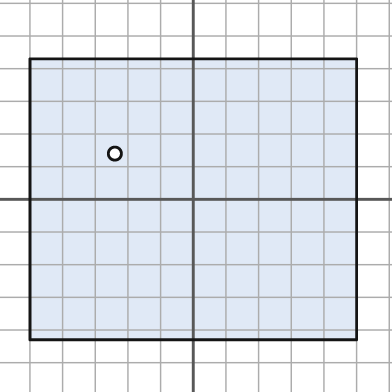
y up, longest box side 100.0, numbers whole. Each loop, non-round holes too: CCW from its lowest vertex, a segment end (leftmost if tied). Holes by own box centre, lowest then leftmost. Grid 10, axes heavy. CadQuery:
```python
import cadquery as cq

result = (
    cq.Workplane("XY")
    .moveTo(-50.0, -43.0)
    .lineTo(50.0, -43.0)
    .lineTo(50.0, 43.0)
    .lineTo(-50.0, 43.0)
    .close()
    .moveTo(-24.0, 14.0)
    .circle(2.0)
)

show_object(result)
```